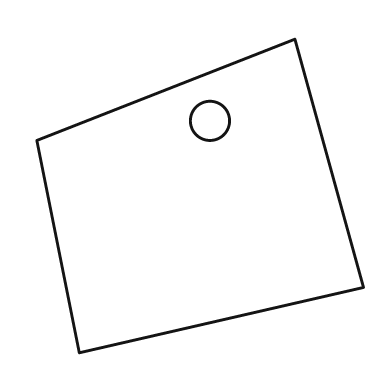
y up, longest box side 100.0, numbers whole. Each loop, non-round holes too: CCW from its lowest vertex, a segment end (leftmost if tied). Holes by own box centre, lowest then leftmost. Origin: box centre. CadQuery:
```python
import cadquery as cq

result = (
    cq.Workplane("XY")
    .moveTo(-37.0, -48.0)
    .lineTo(50.0, -28.0)
    .lineTo(29.0, 48.0)
    .lineTo(-50.0, 17.0)
    .close()
    .moveTo(3.0, 23.0)
    .circle(6.0)
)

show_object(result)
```